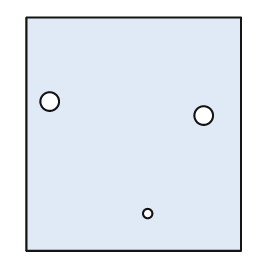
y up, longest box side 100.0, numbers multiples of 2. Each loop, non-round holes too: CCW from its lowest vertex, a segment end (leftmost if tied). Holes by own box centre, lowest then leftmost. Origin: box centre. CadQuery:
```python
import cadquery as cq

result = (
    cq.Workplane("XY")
    .moveTo(-46.0, -50.0)
    .lineTo(46.0, -50.0)
    .lineTo(46.0, 50.0)
    .lineTo(-46.0, 50.0)
    .close()
    .moveTo(6.0, -34.0)
    .circle(2.0)
    .moveTo(30.0, 8.0)
    .circle(4.0)
    .moveTo(-36.0, 14.0)
    .circle(4.0)
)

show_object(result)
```